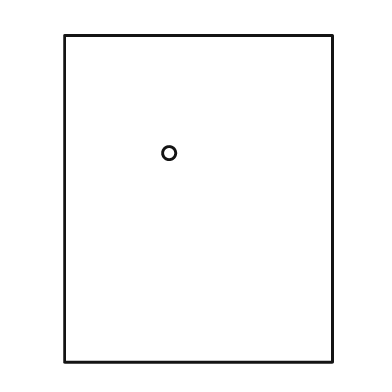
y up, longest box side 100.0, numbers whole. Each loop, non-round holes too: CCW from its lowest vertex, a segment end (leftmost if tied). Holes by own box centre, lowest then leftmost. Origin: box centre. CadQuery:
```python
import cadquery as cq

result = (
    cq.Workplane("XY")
    .moveTo(-41.0, -50.0)
    .lineTo(41.0, -50.0)
    .lineTo(41.0, 50.0)
    .lineTo(-41.0, 50.0)
    .close()
    .moveTo(-9.0, 14.0)
    .circle(2.0)
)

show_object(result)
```